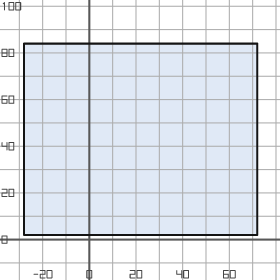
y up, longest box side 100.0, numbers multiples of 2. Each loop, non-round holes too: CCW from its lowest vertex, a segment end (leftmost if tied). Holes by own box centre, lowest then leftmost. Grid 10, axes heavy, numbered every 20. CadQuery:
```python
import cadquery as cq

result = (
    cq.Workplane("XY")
    .moveTo(-28.0, 2.0)
    .lineTo(72.0, 2.0)
    .lineTo(72.0, 84.0)
    .lineTo(-28.0, 84.0)
    .close()
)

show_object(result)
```